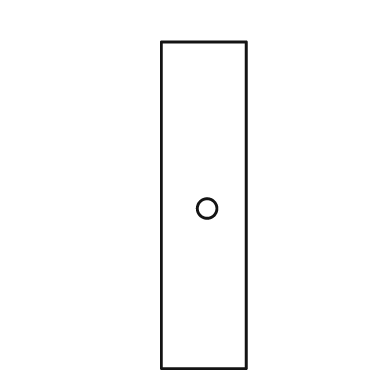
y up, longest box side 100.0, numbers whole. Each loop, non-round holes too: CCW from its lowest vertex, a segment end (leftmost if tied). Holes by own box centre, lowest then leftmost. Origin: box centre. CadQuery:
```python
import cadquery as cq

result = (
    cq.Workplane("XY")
    .moveTo(-13.0, -50.0)
    .lineTo(13.0, -50.0)
    .lineTo(13.0, 50.0)
    .lineTo(-13.0, 50.0)
    .close()
    .moveTo(1.0, -1.0)
    .circle(3.0)
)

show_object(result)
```